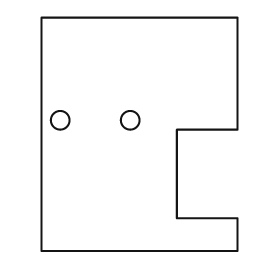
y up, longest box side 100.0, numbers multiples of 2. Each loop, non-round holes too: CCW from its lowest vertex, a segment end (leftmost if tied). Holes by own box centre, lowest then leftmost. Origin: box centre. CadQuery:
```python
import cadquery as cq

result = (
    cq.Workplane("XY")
    .moveTo(-42.0, -50.0)
    .lineTo(42.0, -50.0)
    .lineTo(42.0, -36.0)
    .lineTo(16.0, -36.0)
    .lineTo(16.0, 2.0)
    .lineTo(42.0, 2.0)
    .lineTo(42.0, 50.0)
    .lineTo(-42.0, 50.0)
    .close()
    .moveTo(-34.0, 6.0)
    .circle(4.0)
    .moveTo(-4.0, 6.0)
    .circle(4.0)
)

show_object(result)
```